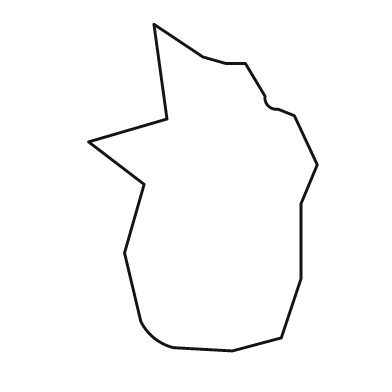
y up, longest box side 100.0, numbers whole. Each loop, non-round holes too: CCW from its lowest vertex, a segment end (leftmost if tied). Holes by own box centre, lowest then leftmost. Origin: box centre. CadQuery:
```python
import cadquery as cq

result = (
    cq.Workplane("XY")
    .moveTo(9.0, -50.0)
    .lineTo(24.0, -46.0)
    .lineTo(30.0, -28.0)
    .lineTo(30.0, -5.0)
    .lineTo(35.0, 7.0)
    .lineTo(28.0, 22.0)
    .lineTo(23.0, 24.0)
    .threePointArc((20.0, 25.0), (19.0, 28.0))
    .lineTo(13.0, 38.0)
    .lineTo(7.0, 38.0)
    .lineTo(0.0, 40.0)
    .lineTo(-15.0, 50.0)
    .lineTo(-11.0, 21.0)
    .lineTo(-35.0, 14.0)
    .lineTo(-18.0, 1.0)
    .lineTo(-24.0, -20.0)
    .lineTo(-19.0, -41.0)
    .threePointArc((-15.0, -46.0), (-9.0, -49.0))
    .close()
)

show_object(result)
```